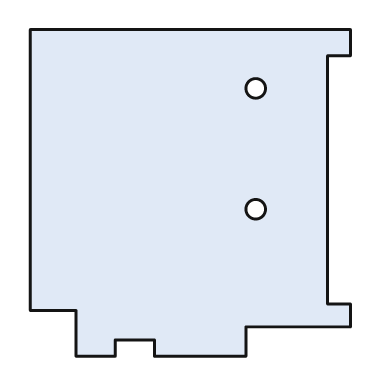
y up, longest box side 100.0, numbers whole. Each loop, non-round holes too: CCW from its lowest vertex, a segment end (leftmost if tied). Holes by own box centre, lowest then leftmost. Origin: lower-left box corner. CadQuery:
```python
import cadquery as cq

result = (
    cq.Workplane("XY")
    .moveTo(14.0, 0.0)
    .lineTo(26.0, 0.0)
    .lineTo(26.0, 5.0)
    .lineTo(38.0, 5.0)
    .lineTo(38.0, 0.0)
    .lineTo(66.0, 0.0)
    .lineTo(66.0, 9.0)
    .lineTo(98.0, 9.0)
    .lineTo(98.0, 16.0)
    .lineTo(91.0, 16.0)
    .lineTo(91.0, 92.0)
    .lineTo(98.0, 92.0)
    .lineTo(98.0, 100.0)
    .lineTo(0.0, 100.0)
    .lineTo(0.0, 14.0)
    .lineTo(14.0, 14.0)
    .close()
    .moveTo(69.0, 45.0)
    .circle(3.0)
    .moveTo(69.0, 82.0)
    .circle(3.0)
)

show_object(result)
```